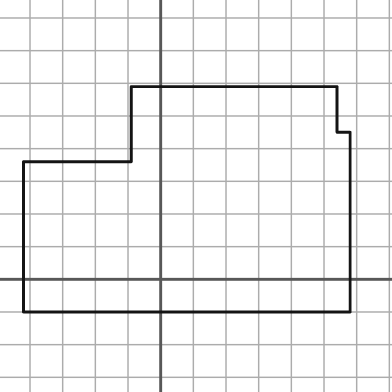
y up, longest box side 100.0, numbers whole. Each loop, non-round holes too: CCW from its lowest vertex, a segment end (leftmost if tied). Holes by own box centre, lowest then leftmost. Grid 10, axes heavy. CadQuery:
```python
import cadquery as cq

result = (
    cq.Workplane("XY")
    .moveTo(-42.0, -10.0)
    .lineTo(58.0, -10.0)
    .lineTo(58.0, 45.0)
    .lineTo(54.0, 45.0)
    .lineTo(54.0, 59.0)
    .lineTo(-9.0, 59.0)
    .lineTo(-9.0, 36.0)
    .lineTo(-42.0, 36.0)
    .close()
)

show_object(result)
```